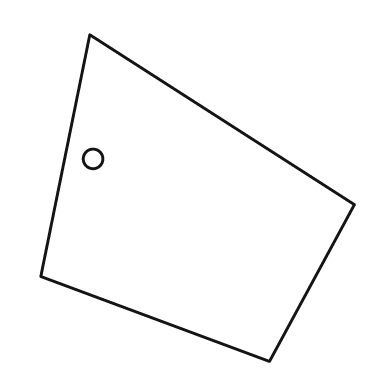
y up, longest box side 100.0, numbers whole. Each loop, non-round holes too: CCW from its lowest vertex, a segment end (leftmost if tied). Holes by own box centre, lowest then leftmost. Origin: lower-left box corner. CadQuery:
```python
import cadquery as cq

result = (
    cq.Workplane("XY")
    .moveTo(70.0, 0.0)
    .lineTo(96.0, 48.0)
    .lineTo(15.0, 100.0)
    .lineTo(0.0, 26.0)
    .close()
    .moveTo(16.0, 62.0)
    .circle(3.0)
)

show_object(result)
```